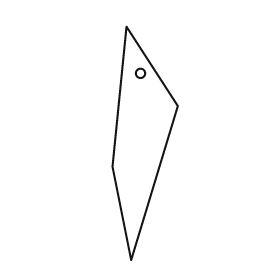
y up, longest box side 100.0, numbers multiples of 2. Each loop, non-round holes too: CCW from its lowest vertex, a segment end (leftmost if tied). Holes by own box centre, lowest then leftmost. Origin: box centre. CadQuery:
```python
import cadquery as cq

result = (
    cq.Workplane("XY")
    .moveTo(-6.0, -50.0)
    .lineTo(14.0, 16.0)
    .lineTo(-8.0, 50.0)
    .lineTo(-14.0, -10.0)
    .close()
    .moveTo(-2.0, 30.0)
    .circle(2.0)
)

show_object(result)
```